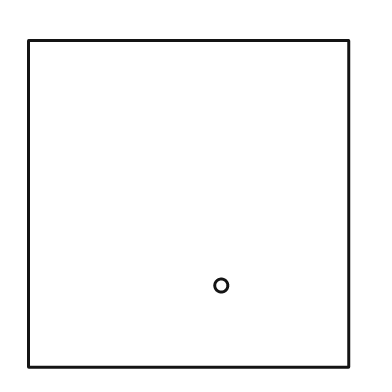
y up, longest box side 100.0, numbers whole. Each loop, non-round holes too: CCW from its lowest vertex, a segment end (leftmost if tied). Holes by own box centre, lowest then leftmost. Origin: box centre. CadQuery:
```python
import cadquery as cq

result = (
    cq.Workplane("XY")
    .moveTo(-49.0, -50.0)
    .lineTo(49.0, -50.0)
    .lineTo(49.0, 50.0)
    .lineTo(-49.0, 50.0)
    .close()
    .moveTo(10.0, -25.0)
    .circle(2.0)
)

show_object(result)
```